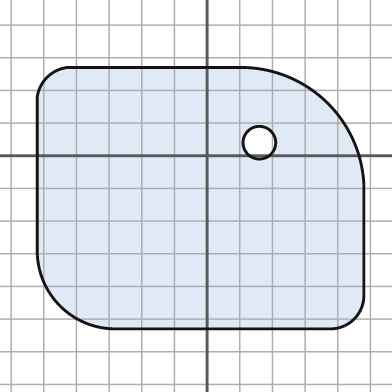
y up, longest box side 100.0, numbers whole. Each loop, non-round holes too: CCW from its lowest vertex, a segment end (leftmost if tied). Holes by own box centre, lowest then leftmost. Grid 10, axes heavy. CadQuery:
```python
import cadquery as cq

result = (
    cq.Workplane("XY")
    .moveTo(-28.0, -53.0)
    .lineTo(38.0, -53.0)
    .threePointArc((45.0, -50.0), (48.0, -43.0))
    .lineTo(48.0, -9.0)
    .threePointArc((37.0, 16.0), (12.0, 27.0))
    .lineTo(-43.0, 27.0)
    .threePointArc((-49.0, 24.0), (-52.0, 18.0))
    .lineTo(-52.0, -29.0)
    .threePointArc((-45.0, -46.0), (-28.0, -53.0))
    .close()
    .moveTo(16.0, 4.0)
    .circle(5.0)
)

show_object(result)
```